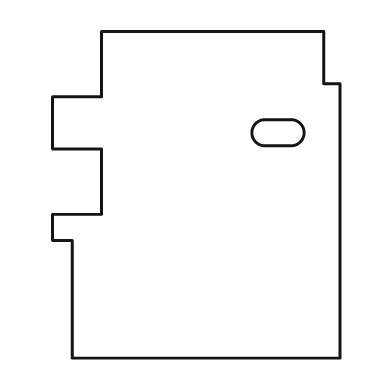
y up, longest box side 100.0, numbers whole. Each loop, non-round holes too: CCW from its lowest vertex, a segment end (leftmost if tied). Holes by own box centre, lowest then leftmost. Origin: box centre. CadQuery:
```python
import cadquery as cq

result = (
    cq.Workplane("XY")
    .moveTo(-38.0, -50.0)
    .lineTo(44.0, -50.0)
    .lineTo(44.0, 34.0)
    .lineTo(39.0, 34.0)
    .lineTo(39.0, 50.0)
    .lineTo(-29.0, 50.0)
    .lineTo(-29.0, 30.0)
    .lineTo(-44.0, 30.0)
    .lineTo(-44.0, 14.0)
    .lineTo(-29.0, 14.0)
    .lineTo(-29.0, -6.0)
    .lineTo(-44.0, -6.0)
    .lineTo(-44.0, -14.0)
    .lineTo(-38.0, -14.0)
    .close()
    .moveTo(21.0, 15.0)
    .lineTo(29.0, 15.0)
    .threePointArc((33.0, 19.0), (29.0, 23.0))
    .lineTo(21.0, 23.0)
    .threePointArc((17.0, 19.0), (21.0, 15.0))
    .close()
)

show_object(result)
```